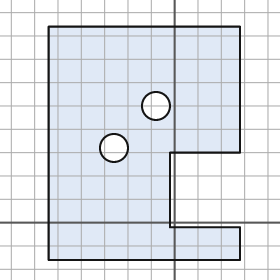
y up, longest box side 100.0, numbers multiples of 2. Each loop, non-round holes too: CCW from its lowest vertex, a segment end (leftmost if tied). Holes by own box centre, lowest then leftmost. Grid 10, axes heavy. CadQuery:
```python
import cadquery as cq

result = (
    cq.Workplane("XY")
    .moveTo(-54.0, -16.0)
    .lineTo(28.0, -16.0)
    .lineTo(28.0, -2.0)
    .lineTo(-2.0, -2.0)
    .lineTo(-2.0, 30.0)
    .lineTo(28.0, 30.0)
    .lineTo(28.0, 84.0)
    .lineTo(-54.0, 84.0)
    .close()
    .moveTo(-26.0, 32.0)
    .circle(6.0)
    .moveTo(-8.0, 50.0)
    .circle(6.0)
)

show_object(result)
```